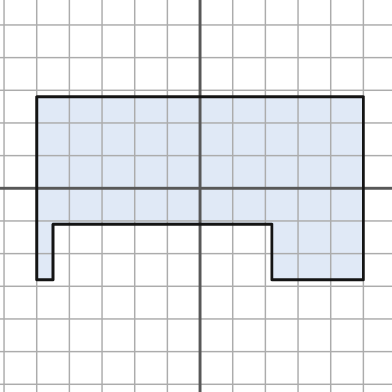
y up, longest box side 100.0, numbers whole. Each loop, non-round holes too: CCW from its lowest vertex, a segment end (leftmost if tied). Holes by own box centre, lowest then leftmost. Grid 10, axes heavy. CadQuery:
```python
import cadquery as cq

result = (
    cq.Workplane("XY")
    .moveTo(-50.0, -28.0)
    .lineTo(-45.0, -28.0)
    .lineTo(-45.0, -11.0)
    .lineTo(22.0, -11.0)
    .lineTo(22.0, -28.0)
    .lineTo(50.0, -28.0)
    .lineTo(50.0, 28.0)
    .lineTo(-50.0, 28.0)
    .close()
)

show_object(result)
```